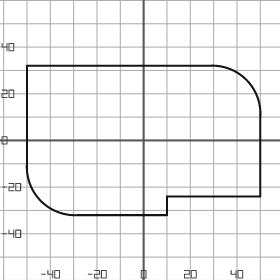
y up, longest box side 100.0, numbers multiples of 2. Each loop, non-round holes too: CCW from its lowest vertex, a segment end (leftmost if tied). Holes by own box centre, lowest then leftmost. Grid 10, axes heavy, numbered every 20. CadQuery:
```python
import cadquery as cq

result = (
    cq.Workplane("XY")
    .moveTo(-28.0, -32.0)
    .lineTo(10.0, -32.0)
    .lineTo(10.0, -24.0)
    .lineTo(50.0, -24.0)
    .lineTo(50.0, 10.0)
    .threePointArc((44.0, 26.0), (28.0, 32.0))
    .lineTo(-50.0, 32.0)
    .lineTo(-50.0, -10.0)
    .threePointArc((-44.0, -26.0), (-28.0, -32.0))
    .close()
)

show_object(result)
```